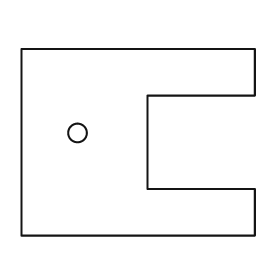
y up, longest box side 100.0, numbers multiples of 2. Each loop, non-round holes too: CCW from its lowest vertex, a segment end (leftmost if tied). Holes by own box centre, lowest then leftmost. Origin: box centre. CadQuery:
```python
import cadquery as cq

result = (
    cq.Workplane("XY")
    .moveTo(-50.0, -40.0)
    .lineTo(50.0, -40.0)
    .lineTo(50.0, -20.0)
    .lineTo(4.0, -20.0)
    .lineTo(4.0, 20.0)
    .lineTo(50.0, 20.0)
    .lineTo(50.0, 40.0)
    .lineTo(-50.0, 40.0)
    .close()
    .moveTo(-26.0, 4.0)
    .circle(4.0)
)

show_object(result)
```